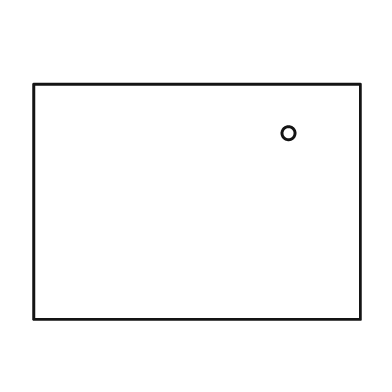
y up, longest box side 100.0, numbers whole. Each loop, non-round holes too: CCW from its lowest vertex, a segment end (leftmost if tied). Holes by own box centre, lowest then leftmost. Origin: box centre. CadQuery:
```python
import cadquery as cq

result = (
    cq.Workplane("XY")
    .moveTo(-50.0, -36.0)
    .lineTo(50.0, -36.0)
    .lineTo(50.0, 36.0)
    .lineTo(-50.0, 36.0)
    .close()
    .moveTo(28.0, 21.0)
    .circle(2.0)
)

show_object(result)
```